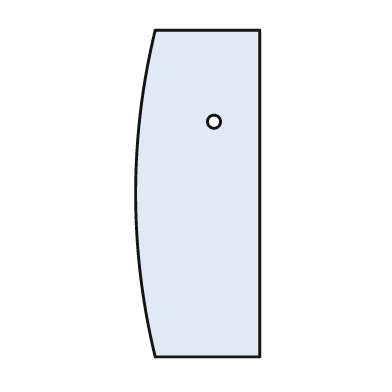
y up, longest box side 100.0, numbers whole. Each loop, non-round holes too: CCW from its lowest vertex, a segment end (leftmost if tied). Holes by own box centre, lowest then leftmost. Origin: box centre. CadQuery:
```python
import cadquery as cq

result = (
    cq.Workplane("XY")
    .moveTo(-13.0, -50.0)
    .lineTo(19.0, -50.0)
    .lineTo(19.0, 50.0)
    .lineTo(-13.0, 50.0)
    .threePointArc((-19.0, 0.0), (-13.0, -50.0))
    .close()
    .moveTo(5.0, 22.0)
    .circle(2.0)
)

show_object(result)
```